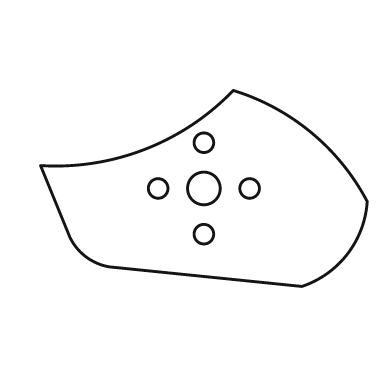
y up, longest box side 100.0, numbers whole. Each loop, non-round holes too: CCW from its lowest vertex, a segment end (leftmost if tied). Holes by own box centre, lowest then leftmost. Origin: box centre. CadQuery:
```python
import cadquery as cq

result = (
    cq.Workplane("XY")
    .moveTo(30.0, -30.0)
    .threePointArc((44.0, -20.0), (50.0, -4.0))
    .threePointArc((33.0, 17.0), (9.0, 30.0))
    .threePointArc((-18.0, 12.0), (-50.0, 7.0))
    .lineTo(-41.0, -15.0)
    .threePointArc((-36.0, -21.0), (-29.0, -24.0))
    .close()
    .moveTo(0.0, -14.0)
    .circle(3.0)
    .moveTo(-14.0, 0.0)
    .circle(3.0)
    .moveTo(0.0, 0.0)
    .circle(5.0)
    .moveTo(14.0, 0.0)
    .circle(3.0)
    .moveTo(0.0, 14.0)
    .circle(3.0)
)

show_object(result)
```